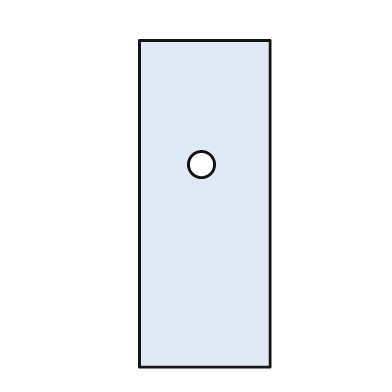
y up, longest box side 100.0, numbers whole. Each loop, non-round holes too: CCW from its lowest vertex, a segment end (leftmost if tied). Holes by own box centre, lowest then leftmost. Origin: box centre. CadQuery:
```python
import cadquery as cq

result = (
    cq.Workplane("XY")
    .moveTo(-20.0, -50.0)
    .lineTo(20.0, -50.0)
    .lineTo(20.0, 50.0)
    .lineTo(-20.0, 50.0)
    .close()
    .moveTo(-1.0, 12.0)
    .circle(4.0)
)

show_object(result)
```